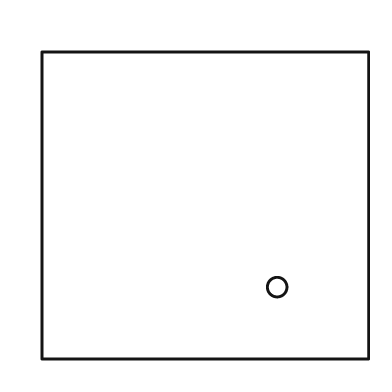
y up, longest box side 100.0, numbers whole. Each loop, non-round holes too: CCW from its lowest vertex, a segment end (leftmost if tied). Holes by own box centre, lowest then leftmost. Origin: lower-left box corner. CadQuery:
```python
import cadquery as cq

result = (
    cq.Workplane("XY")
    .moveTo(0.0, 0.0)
    .lineTo(100.0, 0.0)
    .lineTo(100.0, 94.0)
    .lineTo(0.0, 94.0)
    .close()
    .moveTo(72.0, 22.0)
    .circle(3.0)
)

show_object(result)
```